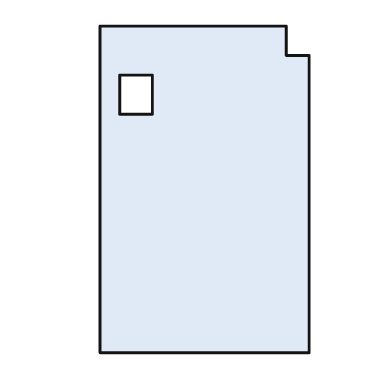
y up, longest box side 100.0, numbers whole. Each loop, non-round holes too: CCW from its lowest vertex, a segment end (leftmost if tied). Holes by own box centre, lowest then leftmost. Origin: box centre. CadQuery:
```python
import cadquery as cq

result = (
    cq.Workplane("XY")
    .moveTo(-32.0, -50.0)
    .lineTo(32.0, -50.0)
    .lineTo(32.0, 41.0)
    .lineTo(25.0, 41.0)
    .lineTo(25.0, 50.0)
    .lineTo(-32.0, 50.0)
    .close()
    .moveTo(-26.0, 23.0)
    .lineTo(-16.0, 23.0)
    .lineTo(-16.0, 35.0)
    .lineTo(-26.0, 35.0)
    .close()
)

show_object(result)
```